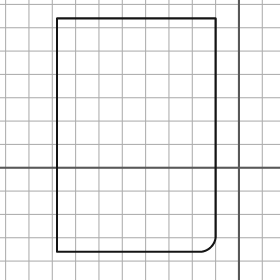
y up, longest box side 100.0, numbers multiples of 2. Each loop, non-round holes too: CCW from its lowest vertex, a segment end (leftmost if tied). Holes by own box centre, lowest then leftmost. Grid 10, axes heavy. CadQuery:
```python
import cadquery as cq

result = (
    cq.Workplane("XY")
    .moveTo(-78.0, -36.0)
    .lineTo(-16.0, -36.0)
    .threePointArc((-12.0, -34.0), (-10.0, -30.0))
    .lineTo(-10.0, 64.0)
    .lineTo(-78.0, 64.0)
    .close()
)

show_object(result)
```